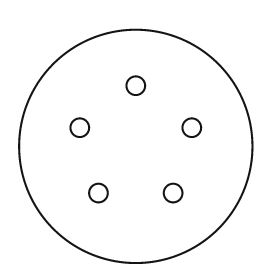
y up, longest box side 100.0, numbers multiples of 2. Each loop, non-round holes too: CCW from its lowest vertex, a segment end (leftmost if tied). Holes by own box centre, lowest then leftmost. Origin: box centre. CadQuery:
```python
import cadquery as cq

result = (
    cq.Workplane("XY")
    .moveTo(0.0, 0.0)
    .circle(50.0)
    .moveTo(-16.0, -20.0)
    .circle(4.0)
    .moveTo(16.0, -20.0)
    .circle(4.0)
    .moveTo(-24.0, 8.0)
    .circle(4.0)
    .moveTo(24.0, 8.0)
    .circle(4.0)
    .moveTo(0.0, 26.0)
    .circle(4.0)
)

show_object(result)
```